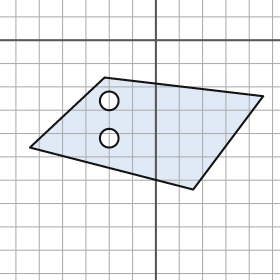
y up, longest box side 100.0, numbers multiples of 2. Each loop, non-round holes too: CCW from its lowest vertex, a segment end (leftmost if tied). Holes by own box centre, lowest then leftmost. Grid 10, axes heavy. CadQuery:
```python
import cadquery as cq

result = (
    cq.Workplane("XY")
    .moveTo(16.0, -64.0)
    .lineTo(46.0, -24.0)
    .lineTo(-22.0, -16.0)
    .lineTo(-54.0, -46.0)
    .close()
    .moveTo(-20.0, -42.0)
    .circle(4.0)
    .moveTo(-20.0, -26.0)
    .circle(4.0)
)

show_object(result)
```